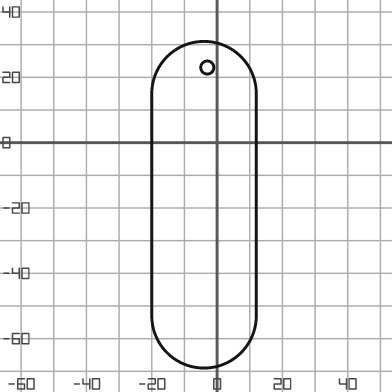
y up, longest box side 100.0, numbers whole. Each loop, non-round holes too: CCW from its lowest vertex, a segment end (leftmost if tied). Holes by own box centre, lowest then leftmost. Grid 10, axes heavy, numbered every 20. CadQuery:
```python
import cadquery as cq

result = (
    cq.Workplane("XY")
    .moveTo(-20.0, -53.0)
    .threePointArc((-4.0, -69.0), (12.0, -53.0))
    .lineTo(12.0, 15.0)
    .threePointArc((-4.0, 31.0), (-20.0, 15.0))
    .close()
    .moveTo(-3.0, 23.0)
    .circle(2.0)
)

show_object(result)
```